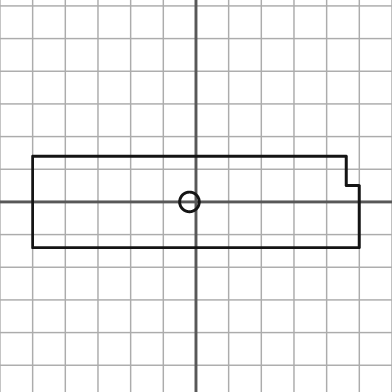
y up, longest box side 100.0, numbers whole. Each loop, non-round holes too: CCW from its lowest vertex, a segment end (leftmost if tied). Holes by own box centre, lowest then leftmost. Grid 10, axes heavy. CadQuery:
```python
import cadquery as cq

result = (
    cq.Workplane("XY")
    .moveTo(-50.0, -14.0)
    .lineTo(50.0, -14.0)
    .lineTo(50.0, 5.0)
    .lineTo(46.0, 5.0)
    .lineTo(46.0, 14.0)
    .lineTo(-50.0, 14.0)
    .close()
    .moveTo(-2.0, 0.0)
    .circle(3.0)
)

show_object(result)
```